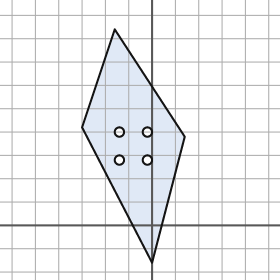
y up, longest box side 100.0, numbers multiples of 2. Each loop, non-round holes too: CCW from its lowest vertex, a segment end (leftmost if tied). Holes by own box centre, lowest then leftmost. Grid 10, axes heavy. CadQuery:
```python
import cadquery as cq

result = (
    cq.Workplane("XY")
    .moveTo(0.0, -16.0)
    .lineTo(14.0, 38.0)
    .lineTo(-16.0, 84.0)
    .lineTo(-30.0, 42.0)
    .close()
    .moveTo(-14.0, 28.0)
    .circle(2.0)
    .moveTo(-2.0, 28.0)
    .circle(2.0)
    .moveTo(-14.0, 40.0)
    .circle(2.0)
    .moveTo(-2.0, 40.0)
    .circle(2.0)
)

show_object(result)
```